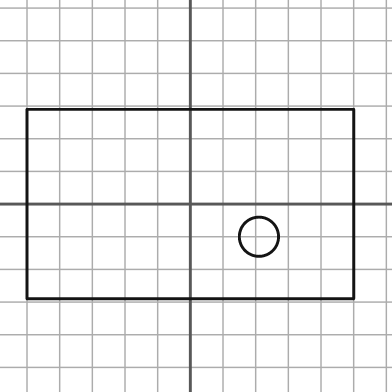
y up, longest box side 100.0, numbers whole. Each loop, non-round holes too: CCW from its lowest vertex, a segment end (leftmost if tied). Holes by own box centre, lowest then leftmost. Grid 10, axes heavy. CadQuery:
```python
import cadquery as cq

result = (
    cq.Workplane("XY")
    .moveTo(-50.0, -29.0)
    .lineTo(50.0, -29.0)
    .lineTo(50.0, 29.0)
    .lineTo(-50.0, 29.0)
    .close()
    .moveTo(21.0, -10.0)
    .circle(6.0)
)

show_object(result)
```